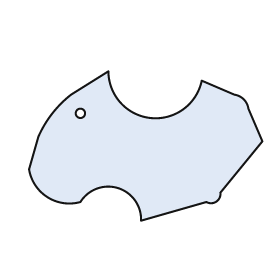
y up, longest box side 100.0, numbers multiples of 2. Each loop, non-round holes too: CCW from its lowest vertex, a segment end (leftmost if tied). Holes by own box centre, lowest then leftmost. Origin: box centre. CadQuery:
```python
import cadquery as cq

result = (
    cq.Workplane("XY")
    .moveTo(-2.0, -32.0)
    .lineTo(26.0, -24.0)
    .threePointArc((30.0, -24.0), (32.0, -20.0))
    .lineTo(50.0, 2.0)
    .lineTo(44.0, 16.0)
    .threePointArc((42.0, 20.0), (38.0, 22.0))
    .lineTo(24.0, 28.0)
    .threePointArc((2.0, 12.0), (-16.0, 32.0))
    .lineTo(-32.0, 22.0)
    .threePointArc((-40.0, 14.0), (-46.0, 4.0))
    .lineTo(-50.0, -10.0)
    .threePointArc((-42.0, -22.0), (-28.0, -24.0))
    .threePointArc((-12.0, -18.0), (-2.0, -32.0))
    .close()
    .moveTo(-28.0, 14.0)
    .circle(2.0)
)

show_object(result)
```